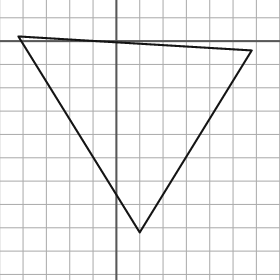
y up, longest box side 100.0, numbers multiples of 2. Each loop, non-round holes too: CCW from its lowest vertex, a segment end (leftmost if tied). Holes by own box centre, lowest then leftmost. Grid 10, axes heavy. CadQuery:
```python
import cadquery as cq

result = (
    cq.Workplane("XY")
    .moveTo(10.0, -82.0)
    .lineTo(58.0, -4.0)
    .lineTo(-42.0, 2.0)
    .close()
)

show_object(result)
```